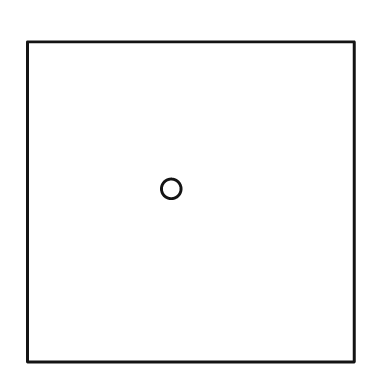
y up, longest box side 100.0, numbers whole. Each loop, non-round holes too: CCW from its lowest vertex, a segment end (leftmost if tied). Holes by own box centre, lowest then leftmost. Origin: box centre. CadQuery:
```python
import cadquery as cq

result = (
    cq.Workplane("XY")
    .moveTo(-50.0, -49.0)
    .lineTo(50.0, -49.0)
    .lineTo(50.0, 49.0)
    .lineTo(-50.0, 49.0)
    .close()
    .moveTo(-6.0, 4.0)
    .circle(3.0)
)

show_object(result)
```